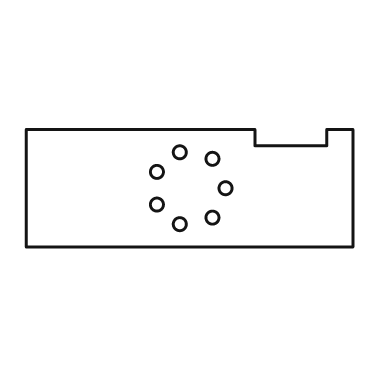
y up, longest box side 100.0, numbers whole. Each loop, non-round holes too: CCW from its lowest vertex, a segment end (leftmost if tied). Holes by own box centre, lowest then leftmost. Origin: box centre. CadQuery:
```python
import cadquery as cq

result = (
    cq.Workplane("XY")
    .moveTo(-50.0, -18.0)
    .lineTo(50.0, -18.0)
    .lineTo(50.0, 18.0)
    .lineTo(42.0, 18.0)
    .lineTo(42.0, 13.0)
    .lineTo(20.0, 13.0)
    .lineTo(20.0, 18.0)
    .lineTo(-50.0, 18.0)
    .close()
    .moveTo(-3.0, -11.0)
    .circle(2.0)
    .moveTo(7.0, -9.0)
    .circle(2.0)
    .moveTo(-10.0, -5.0)
    .circle(2.0)
    .moveTo(11.0, 0.0)
    .circle(2.0)
    .moveTo(-10.0, 5.0)
    .circle(2.0)
    .moveTo(7.0, 9.0)
    .circle(2.0)
    .moveTo(-3.0, 11.0)
    .circle(2.0)
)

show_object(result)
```